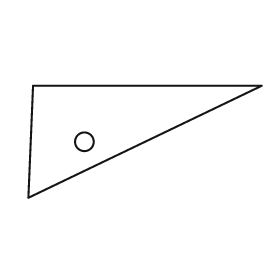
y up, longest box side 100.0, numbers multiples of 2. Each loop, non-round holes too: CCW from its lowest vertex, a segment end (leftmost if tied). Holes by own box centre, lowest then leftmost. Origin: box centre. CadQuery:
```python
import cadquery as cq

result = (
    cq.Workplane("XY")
    .moveTo(-50.0, -24.0)
    .lineTo(50.0, 24.0)
    .lineTo(-48.0, 24.0)
    .close()
    .moveTo(-26.0, 0.0)
    .circle(4.0)
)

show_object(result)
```